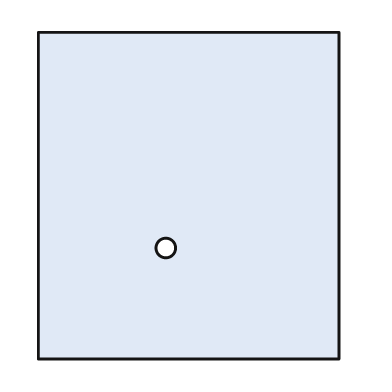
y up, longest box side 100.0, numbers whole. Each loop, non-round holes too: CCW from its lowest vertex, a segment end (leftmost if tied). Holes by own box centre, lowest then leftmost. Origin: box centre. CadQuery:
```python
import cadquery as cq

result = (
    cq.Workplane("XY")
    .moveTo(-46.0, -50.0)
    .lineTo(46.0, -50.0)
    .lineTo(46.0, 50.0)
    .lineTo(-46.0, 50.0)
    .close()
    .moveTo(-7.0, -16.0)
    .circle(3.0)
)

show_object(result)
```